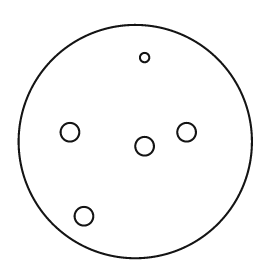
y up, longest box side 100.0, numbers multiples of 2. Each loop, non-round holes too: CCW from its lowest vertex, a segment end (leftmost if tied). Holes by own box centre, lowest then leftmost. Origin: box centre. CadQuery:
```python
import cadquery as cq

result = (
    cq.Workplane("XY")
    .moveTo(0.0, 0.0)
    .circle(50.0)
    .moveTo(-22.0, -32.0)
    .circle(4.0)
    .moveTo(4.0, -2.0)
    .circle(4.0)
    .moveTo(-28.0, 4.0)
    .circle(4.0)
    .moveTo(22.0, 4.0)
    .circle(4.0)
    .moveTo(4.0, 36.0)
    .circle(2.0)
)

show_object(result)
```